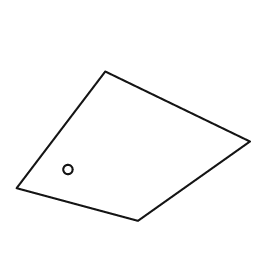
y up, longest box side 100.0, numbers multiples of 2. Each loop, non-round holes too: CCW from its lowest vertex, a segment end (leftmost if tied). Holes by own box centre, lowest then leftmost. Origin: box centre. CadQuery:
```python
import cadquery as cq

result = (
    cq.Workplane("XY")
    .moveTo(2.0, -32.0)
    .lineTo(50.0, 2.0)
    .lineTo(-12.0, 32.0)
    .lineTo(-50.0, -18.0)
    .close()
    .moveTo(-28.0, -10.0)
    .circle(2.0)
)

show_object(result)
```